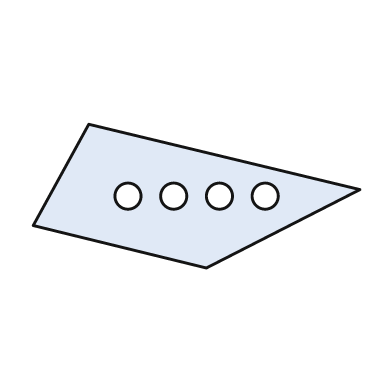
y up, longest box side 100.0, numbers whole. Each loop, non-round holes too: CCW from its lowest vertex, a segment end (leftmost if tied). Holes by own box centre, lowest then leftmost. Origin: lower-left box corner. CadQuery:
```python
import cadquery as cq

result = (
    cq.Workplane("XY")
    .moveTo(53.0, 0.0)
    .lineTo(100.0, 24.0)
    .lineTo(17.0, 44.0)
    .lineTo(0.0, 13.0)
    .close()
    .moveTo(29.0, 22.0)
    .circle(4.0)
    .moveTo(43.0, 22.0)
    .circle(4.0)
    .moveTo(57.0, 22.0)
    .circle(4.0)
    .moveTo(71.0, 22.0)
    .circle(4.0)
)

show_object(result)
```